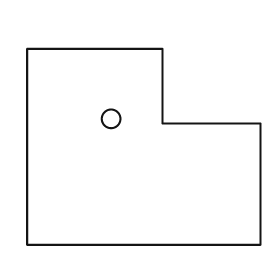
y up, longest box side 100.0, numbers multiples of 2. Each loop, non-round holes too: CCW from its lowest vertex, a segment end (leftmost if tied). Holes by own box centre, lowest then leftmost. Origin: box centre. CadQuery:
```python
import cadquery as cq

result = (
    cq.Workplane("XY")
    .moveTo(-50.0, -42.0)
    .lineTo(50.0, -42.0)
    .lineTo(50.0, 10.0)
    .lineTo(8.0, 10.0)
    .lineTo(8.0, 42.0)
    .lineTo(-50.0, 42.0)
    .close()
    .moveTo(-14.0, 12.0)
    .circle(4.0)
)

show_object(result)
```